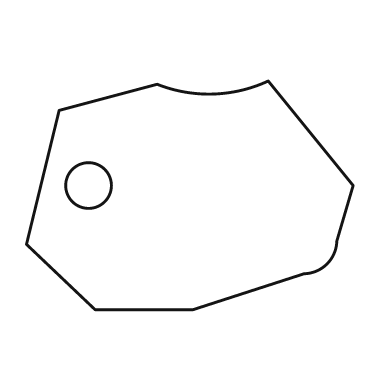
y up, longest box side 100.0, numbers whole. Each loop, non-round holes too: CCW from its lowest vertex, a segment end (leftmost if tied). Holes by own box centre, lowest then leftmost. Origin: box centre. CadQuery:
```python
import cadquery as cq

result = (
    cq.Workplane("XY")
    .moveTo(-29.0, -35.0)
    .lineTo(1.0, -35.0)
    .lineTo(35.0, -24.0)
    .threePointArc((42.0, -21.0), (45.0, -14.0))
    .lineTo(50.0, 3.0)
    .lineTo(24.0, 35.0)
    .threePointArc((7.0, 31.0), (-10.0, 34.0))
    .lineTo(-40.0, 26.0)
    .lineTo(-50.0, -15.0)
    .close()
    .moveTo(-31.0, 3.0)
    .circle(7.0)
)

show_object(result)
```